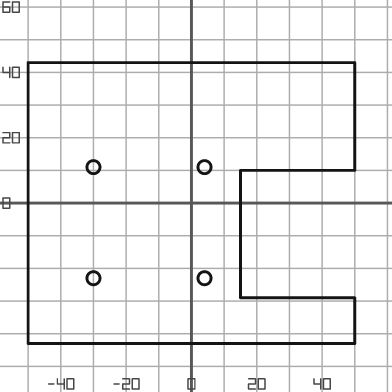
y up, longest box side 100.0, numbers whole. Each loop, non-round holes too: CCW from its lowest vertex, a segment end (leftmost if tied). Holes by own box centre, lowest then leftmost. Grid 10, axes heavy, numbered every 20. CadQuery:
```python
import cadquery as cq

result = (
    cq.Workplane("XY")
    .moveTo(-50.0, -43.0)
    .lineTo(50.0, -43.0)
    .lineTo(50.0, -29.0)
    .lineTo(15.0, -29.0)
    .lineTo(15.0, 10.0)
    .lineTo(50.0, 10.0)
    .lineTo(50.0, 43.0)
    .lineTo(-50.0, 43.0)
    .close()
    .moveTo(-30.0, -23.0)
    .circle(2.0)
    .moveTo(4.0, -23.0)
    .circle(2.0)
    .moveTo(-30.0, 11.0)
    .circle(2.0)
    .moveTo(4.0, 11.0)
    .circle(2.0)
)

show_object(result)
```